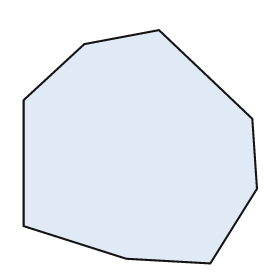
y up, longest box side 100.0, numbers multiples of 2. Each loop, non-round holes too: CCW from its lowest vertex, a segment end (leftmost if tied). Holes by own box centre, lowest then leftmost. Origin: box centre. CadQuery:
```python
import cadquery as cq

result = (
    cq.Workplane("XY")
    .moveTo(30.0, -50.0)
    .lineTo(50.0, -18.0)
    .lineTo(48.0, 12.0)
    .lineTo(8.0, 50.0)
    .lineTo(-24.0, 44.0)
    .lineTo(-50.0, 20.0)
    .lineTo(-50.0, -34.0)
    .lineTo(-6.0, -48.0)
    .close()
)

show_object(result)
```